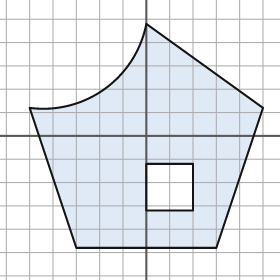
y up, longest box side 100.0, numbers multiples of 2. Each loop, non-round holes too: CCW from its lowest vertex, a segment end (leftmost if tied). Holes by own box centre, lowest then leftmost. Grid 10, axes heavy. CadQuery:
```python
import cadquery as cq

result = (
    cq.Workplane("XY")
    .moveTo(-30.0, -48.0)
    .lineTo(30.0, -48.0)
    .lineTo(50.0, 12.0)
    .lineTo(0.0, 48.0)
    .threePointArc((-18.0, 20.0), (-50.0, 12.0))
    .close()
    .moveTo(0.0, -32.0)
    .lineTo(20.0, -32.0)
    .lineTo(20.0, -12.0)
    .lineTo(0.0, -12.0)
    .close()
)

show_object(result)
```